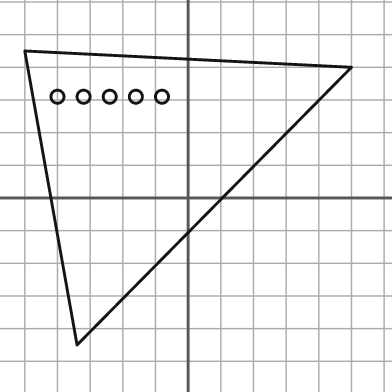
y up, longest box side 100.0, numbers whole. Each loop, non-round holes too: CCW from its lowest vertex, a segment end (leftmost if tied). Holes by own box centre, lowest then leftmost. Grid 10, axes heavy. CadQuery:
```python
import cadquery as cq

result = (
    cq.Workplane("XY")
    .moveTo(-34.0, -45.0)
    .lineTo(50.0, 40.0)
    .lineTo(-50.0, 45.0)
    .close()
    .moveTo(-40.0, 31.0)
    .circle(2.0)
    .moveTo(-32.0, 31.0)
    .circle(2.0)
    .moveTo(-24.0, 31.0)
    .circle(2.0)
    .moveTo(-16.0, 31.0)
    .circle(2.0)
    .moveTo(-8.0, 31.0)
    .circle(2.0)
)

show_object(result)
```